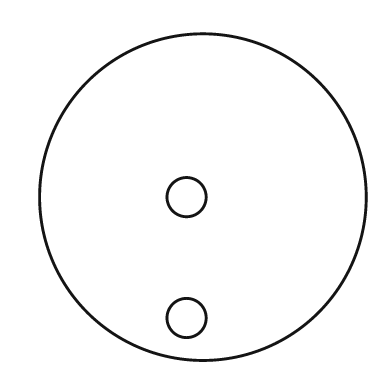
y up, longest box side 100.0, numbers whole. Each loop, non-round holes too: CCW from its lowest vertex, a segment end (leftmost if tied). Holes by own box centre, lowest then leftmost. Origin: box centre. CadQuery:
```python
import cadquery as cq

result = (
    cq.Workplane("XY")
    .moveTo(0.0, 0.0)
    .circle(50.0)
    .moveTo(-5.0, -37.0)
    .circle(6.0)
    .moveTo(-5.0, 0.0)
    .circle(6.0)
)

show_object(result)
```